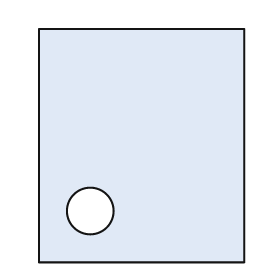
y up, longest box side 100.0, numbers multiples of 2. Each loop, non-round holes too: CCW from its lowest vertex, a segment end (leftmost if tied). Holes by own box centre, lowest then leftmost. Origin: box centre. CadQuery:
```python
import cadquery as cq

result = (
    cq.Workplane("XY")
    .moveTo(-44.0, -50.0)
    .lineTo(44.0, -50.0)
    .lineTo(44.0, 50.0)
    .lineTo(-44.0, 50.0)
    .close()
    .moveTo(-22.0, -28.0)
    .circle(10.0)
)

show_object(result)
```